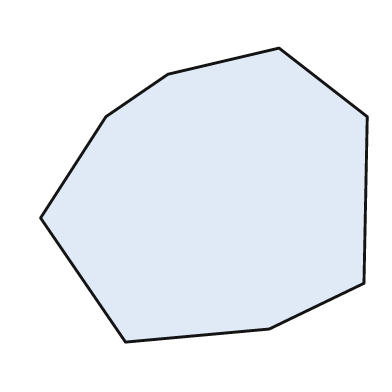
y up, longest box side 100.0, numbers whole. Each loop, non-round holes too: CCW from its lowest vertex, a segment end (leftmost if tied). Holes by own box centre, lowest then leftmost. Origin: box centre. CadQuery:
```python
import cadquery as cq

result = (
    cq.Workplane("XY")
    .moveTo(-24.0, -45.0)
    .lineTo(20.0, -41.0)
    .lineTo(49.0, -27.0)
    .lineTo(50.0, 24.0)
    .lineTo(23.0, 45.0)
    .lineTo(-11.0, 37.0)
    .lineTo(-30.0, 24.0)
    .lineTo(-50.0, -7.0)
    .close()
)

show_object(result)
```